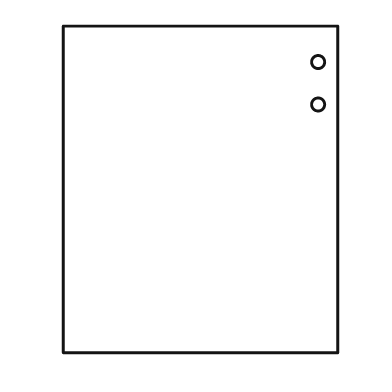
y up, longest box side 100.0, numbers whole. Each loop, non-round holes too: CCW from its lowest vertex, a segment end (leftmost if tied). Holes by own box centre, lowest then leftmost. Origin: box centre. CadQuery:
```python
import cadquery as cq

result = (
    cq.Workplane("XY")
    .moveTo(-42.0, -50.0)
    .lineTo(42.0, -50.0)
    .lineTo(42.0, 50.0)
    .lineTo(-42.0, 50.0)
    .close()
    .moveTo(36.0, 26.0)
    .circle(2.0)
    .moveTo(36.0, 39.0)
    .circle(2.0)
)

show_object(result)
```